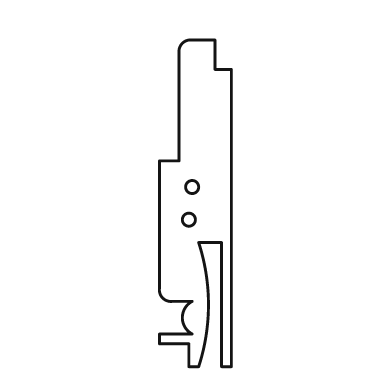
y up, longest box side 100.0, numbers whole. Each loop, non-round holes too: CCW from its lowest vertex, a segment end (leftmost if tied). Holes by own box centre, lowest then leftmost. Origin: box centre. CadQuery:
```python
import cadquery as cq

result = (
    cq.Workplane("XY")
    .moveTo(-2.0, -50.0)
    .lineTo(1.0, -50.0)
    .threePointArc((4.0, -31.0), (1.0, -12.0))
    .lineTo(8.0, -12.0)
    .lineTo(8.0, -50.0)
    .lineTo(11.0, -50.0)
    .lineTo(11.0, 41.0)
    .lineTo(6.0, 41.0)
    .lineTo(6.0, 50.0)
    .lineTo(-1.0, 50.0)
    .threePointArc((-4.0, 49.0), (-5.0, 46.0))
    .lineTo(-5.0, 13.0)
    .lineTo(-11.0, 13.0)
    .lineTo(-11.0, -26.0)
    .threePointArc((-10.0, -29.0), (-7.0, -30.0))
    .lineTo(-1.0, -30.0)
    .threePointArc((-4.0, -35.0), (-1.0, -40.0))
    .lineTo(-11.0, -40.0)
    .lineTo(-11.0, -43.0)
    .lineTo(-2.0, -43.0)
    .close()
    .moveTo(-2.0, -5.0)
    .circle(2.0)
    .moveTo(-1.0, 5.0)
    .circle(2.0)
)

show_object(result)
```